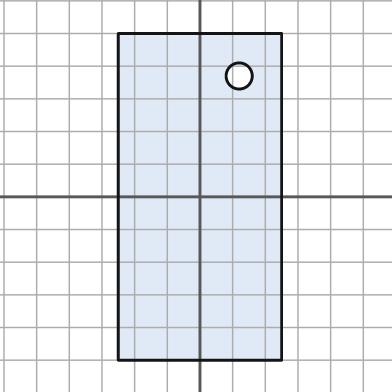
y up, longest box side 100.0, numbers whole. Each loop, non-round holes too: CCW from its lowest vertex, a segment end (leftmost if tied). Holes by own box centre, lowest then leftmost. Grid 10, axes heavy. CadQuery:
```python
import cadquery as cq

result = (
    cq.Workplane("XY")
    .moveTo(-25.0, -50.0)
    .lineTo(25.0, -50.0)
    .lineTo(25.0, 50.0)
    .lineTo(-25.0, 50.0)
    .close()
    .moveTo(12.0, 37.0)
    .circle(4.0)
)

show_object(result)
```